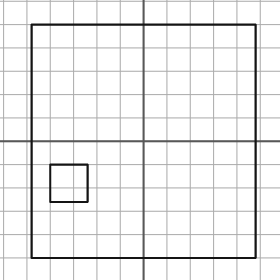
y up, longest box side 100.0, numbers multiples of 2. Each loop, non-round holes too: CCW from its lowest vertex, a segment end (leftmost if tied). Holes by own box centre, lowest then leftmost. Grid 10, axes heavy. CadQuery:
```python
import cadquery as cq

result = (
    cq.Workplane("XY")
    .moveTo(-48.0, -50.0)
    .lineTo(48.0, -50.0)
    .lineTo(48.0, 50.0)
    .lineTo(-48.0, 50.0)
    .close()
    .moveTo(-40.0, -26.0)
    .lineTo(-24.0, -26.0)
    .lineTo(-24.0, -10.0)
    .lineTo(-40.0, -10.0)
    .close()
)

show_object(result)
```